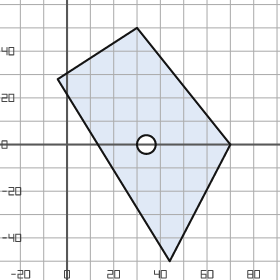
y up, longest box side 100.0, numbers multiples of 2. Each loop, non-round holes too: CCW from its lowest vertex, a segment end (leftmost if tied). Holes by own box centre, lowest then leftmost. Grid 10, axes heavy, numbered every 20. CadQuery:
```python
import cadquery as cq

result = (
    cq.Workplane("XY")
    .moveTo(44.0, -50.0)
    .lineTo(70.0, 0.0)
    .lineTo(30.0, 50.0)
    .lineTo(-4.0, 28.0)
    .close()
    .moveTo(34.0, 0.0)
    .circle(4.0)
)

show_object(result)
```